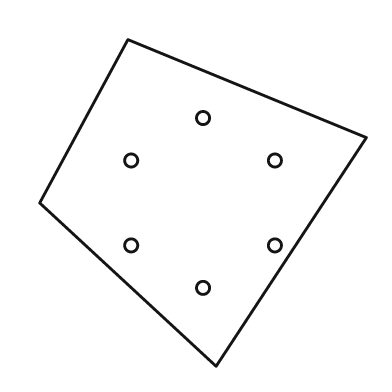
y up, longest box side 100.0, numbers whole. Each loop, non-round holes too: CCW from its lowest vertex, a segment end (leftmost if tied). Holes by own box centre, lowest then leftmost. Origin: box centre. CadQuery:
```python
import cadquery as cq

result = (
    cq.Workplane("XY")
    .moveTo(4.0, -50.0)
    .lineTo(50.0, 20.0)
    .lineTo(-23.0, 50.0)
    .lineTo(-50.0, 0.0)
    .close()
    .moveTo(0.0, -26.0)
    .circle(2.0)
    .moveTo(-22.0, -13.0)
    .circle(2.0)
    .moveTo(22.0, -13.0)
    .circle(2.0)
    .moveTo(-22.0, 13.0)
    .circle(2.0)
    .moveTo(22.0, 13.0)
    .circle(2.0)
    .moveTo(0.0, 26.0)
    .circle(2.0)
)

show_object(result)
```